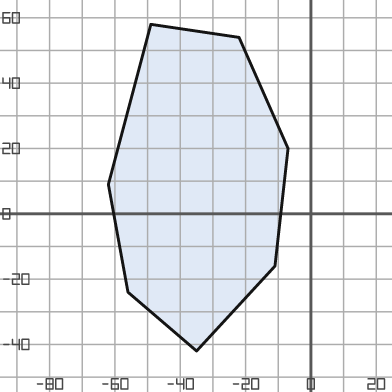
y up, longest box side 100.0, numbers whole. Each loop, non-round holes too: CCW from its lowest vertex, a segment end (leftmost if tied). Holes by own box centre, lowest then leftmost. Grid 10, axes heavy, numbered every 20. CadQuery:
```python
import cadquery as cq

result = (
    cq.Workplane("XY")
    .moveTo(-35.0, -42.0)
    .lineTo(-11.0, -16.0)
    .lineTo(-7.0, 20.0)
    .lineTo(-22.0, 54.0)
    .lineTo(-49.0, 58.0)
    .lineTo(-62.0, 9.0)
    .lineTo(-56.0, -24.0)
    .close()
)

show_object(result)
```